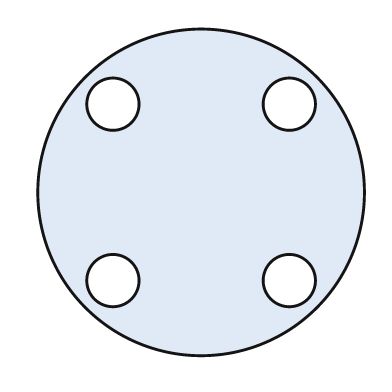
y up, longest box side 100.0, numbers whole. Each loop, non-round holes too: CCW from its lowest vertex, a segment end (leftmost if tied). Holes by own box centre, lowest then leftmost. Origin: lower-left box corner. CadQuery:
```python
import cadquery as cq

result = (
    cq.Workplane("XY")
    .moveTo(50.0, 50.0)
    .circle(50.0)
    .moveTo(23.0, 23.0)
    .circle(8.0)
    .moveTo(77.0, 23.0)
    .circle(8.0)
    .moveTo(23.0, 77.0)
    .circle(8.0)
    .moveTo(77.0, 77.0)
    .circle(8.0)
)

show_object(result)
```